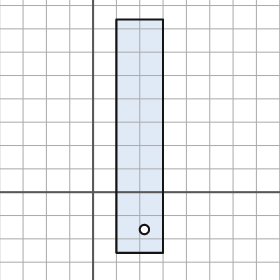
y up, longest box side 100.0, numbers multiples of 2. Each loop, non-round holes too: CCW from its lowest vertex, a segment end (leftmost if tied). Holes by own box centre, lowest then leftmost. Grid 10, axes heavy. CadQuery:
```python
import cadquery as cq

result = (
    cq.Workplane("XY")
    .moveTo(10.0, -26.0)
    .lineTo(30.0, -26.0)
    .lineTo(30.0, 74.0)
    .lineTo(10.0, 74.0)
    .close()
    .moveTo(22.0, -16.0)
    .circle(2.0)
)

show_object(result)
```